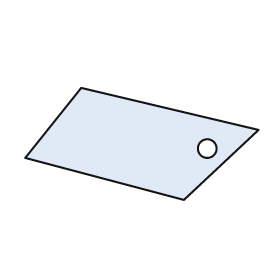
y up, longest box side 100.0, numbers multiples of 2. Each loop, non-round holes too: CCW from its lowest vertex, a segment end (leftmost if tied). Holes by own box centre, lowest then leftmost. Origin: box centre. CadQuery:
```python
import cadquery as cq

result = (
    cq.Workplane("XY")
    .moveTo(18.0, -24.0)
    .lineTo(50.0, 6.0)
    .lineTo(-26.0, 24.0)
    .lineTo(-50.0, -6.0)
    .close()
    .moveTo(28.0, -2.0)
    .circle(4.0)
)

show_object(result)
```